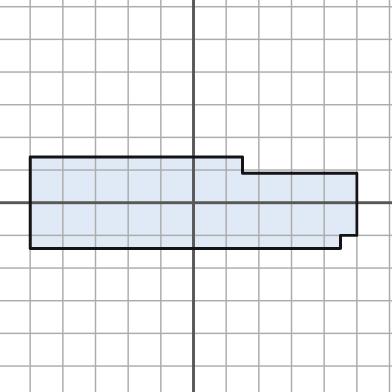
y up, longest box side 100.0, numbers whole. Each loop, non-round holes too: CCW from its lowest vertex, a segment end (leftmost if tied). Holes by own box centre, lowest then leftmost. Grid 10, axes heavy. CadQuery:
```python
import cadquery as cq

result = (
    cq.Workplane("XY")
    .moveTo(-50.0, -14.0)
    .lineTo(45.0, -14.0)
    .lineTo(45.0, -10.0)
    .lineTo(50.0, -10.0)
    .lineTo(50.0, 9.0)
    .lineTo(15.0, 9.0)
    .lineTo(15.0, 14.0)
    .lineTo(-50.0, 14.0)
    .close()
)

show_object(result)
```